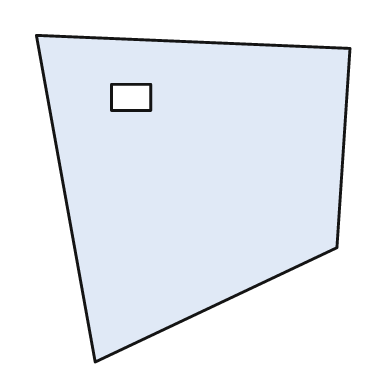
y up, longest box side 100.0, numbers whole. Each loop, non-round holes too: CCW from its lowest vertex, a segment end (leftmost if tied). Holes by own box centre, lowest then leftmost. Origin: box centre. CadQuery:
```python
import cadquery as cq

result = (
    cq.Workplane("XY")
    .moveTo(-30.0, -50.0)
    .lineTo(44.0, -15.0)
    .lineTo(48.0, 46.0)
    .lineTo(-48.0, 50.0)
    .close()
    .moveTo(-25.0, 27.0)
    .lineTo(-13.0, 27.0)
    .lineTo(-13.0, 35.0)
    .lineTo(-25.0, 35.0)
    .close()
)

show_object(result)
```